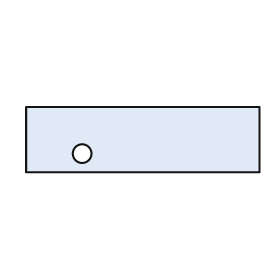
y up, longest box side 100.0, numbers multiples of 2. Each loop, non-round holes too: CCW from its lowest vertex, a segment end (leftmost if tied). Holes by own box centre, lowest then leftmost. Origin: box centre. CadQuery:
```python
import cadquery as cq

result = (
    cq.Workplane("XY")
    .moveTo(-50.0, -14.0)
    .lineTo(50.0, -14.0)
    .lineTo(50.0, 14.0)
    .lineTo(-50.0, 14.0)
    .close()
    .moveTo(-26.0, -6.0)
    .circle(4.0)
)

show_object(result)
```